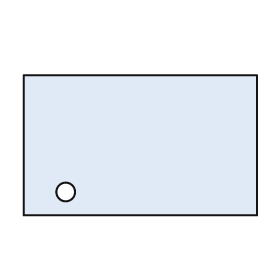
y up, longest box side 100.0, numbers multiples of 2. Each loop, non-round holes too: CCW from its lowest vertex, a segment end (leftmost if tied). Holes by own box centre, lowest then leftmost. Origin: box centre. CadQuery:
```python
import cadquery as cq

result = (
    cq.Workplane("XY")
    .moveTo(-50.0, -30.0)
    .lineTo(50.0, -30.0)
    .lineTo(50.0, 30.0)
    .lineTo(-50.0, 30.0)
    .close()
    .moveTo(-32.0, -20.0)
    .circle(4.0)
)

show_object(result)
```